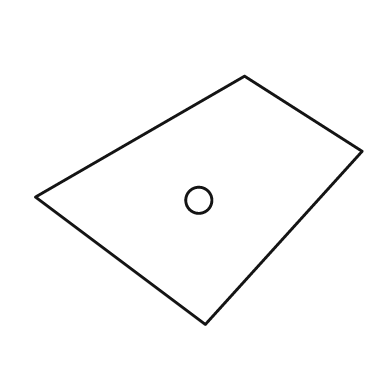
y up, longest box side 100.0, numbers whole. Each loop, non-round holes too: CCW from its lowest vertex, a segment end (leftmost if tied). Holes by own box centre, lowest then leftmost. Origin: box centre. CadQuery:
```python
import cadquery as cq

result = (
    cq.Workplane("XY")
    .moveTo(2.0, -38.0)
    .lineTo(50.0, 15.0)
    .lineTo(14.0, 38.0)
    .lineTo(-50.0, 1.0)
    .close()
    .moveTo(0.0, 0.0)
    .circle(4.0)
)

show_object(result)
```